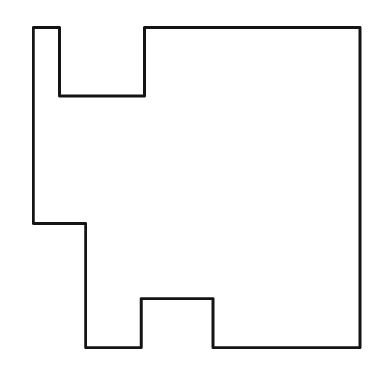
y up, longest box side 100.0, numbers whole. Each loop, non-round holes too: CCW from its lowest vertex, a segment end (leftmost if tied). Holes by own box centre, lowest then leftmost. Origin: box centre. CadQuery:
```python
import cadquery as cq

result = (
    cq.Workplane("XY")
    .moveTo(-34.0, -49.0)
    .lineTo(-17.0, -49.0)
    .lineTo(-17.0, -34.0)
    .lineTo(5.0, -34.0)
    .lineTo(5.0, -49.0)
    .lineTo(50.0, -49.0)
    .lineTo(50.0, 49.0)
    .lineTo(-16.0, 49.0)
    .lineTo(-16.0, 28.0)
    .lineTo(-42.0, 28.0)
    .lineTo(-42.0, 49.0)
    .lineTo(-50.0, 49.0)
    .lineTo(-50.0, -11.0)
    .lineTo(-34.0, -11.0)
    .close()
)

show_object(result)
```